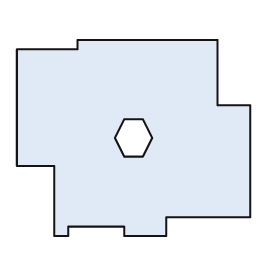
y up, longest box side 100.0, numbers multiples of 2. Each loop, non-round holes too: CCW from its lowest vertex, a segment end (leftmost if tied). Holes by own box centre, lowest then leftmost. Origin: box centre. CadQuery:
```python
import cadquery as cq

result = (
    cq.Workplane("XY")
    .moveTo(-34.0, -42.0)
    .lineTo(-28.0, -42.0)
    .lineTo(-28.0, -38.0)
    .lineTo(-4.0, -38.0)
    .lineTo(-4.0, -42.0)
    .lineTo(14.0, -42.0)
    .lineTo(14.0, -34.0)
    .lineTo(50.0, -34.0)
    .lineTo(50.0, 14.0)
    .lineTo(36.0, 14.0)
    .lineTo(36.0, 42.0)
    .lineTo(-24.0, 42.0)
    .lineTo(-24.0, 38.0)
    .lineTo(-50.0, 38.0)
    .lineTo(-50.0, -12.0)
    .lineTo(-34.0, -12.0)
    .close()
    .moveTo(-4.0, -8.0)
    .lineTo(4.0, -8.0)
    .lineTo(8.0, 0.0)
    .lineTo(4.0, 8.0)
    .lineTo(-4.0, 8.0)
    .lineTo(-8.0, 0.0)
    .close()
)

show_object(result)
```